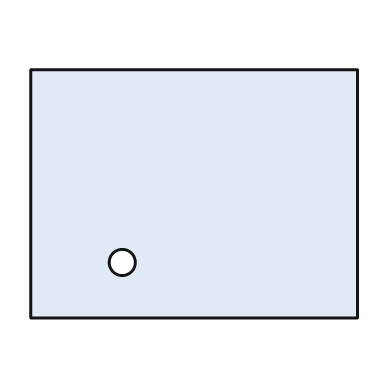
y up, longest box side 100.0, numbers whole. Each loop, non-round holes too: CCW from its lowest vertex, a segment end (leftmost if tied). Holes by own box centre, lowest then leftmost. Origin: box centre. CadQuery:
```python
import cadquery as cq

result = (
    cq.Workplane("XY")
    .moveTo(-50.0, -38.0)
    .lineTo(50.0, -38.0)
    .lineTo(50.0, 38.0)
    .lineTo(-50.0, 38.0)
    .close()
    .moveTo(-22.0, -21.0)
    .circle(4.0)
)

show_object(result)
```